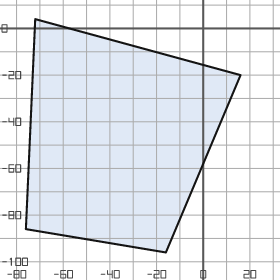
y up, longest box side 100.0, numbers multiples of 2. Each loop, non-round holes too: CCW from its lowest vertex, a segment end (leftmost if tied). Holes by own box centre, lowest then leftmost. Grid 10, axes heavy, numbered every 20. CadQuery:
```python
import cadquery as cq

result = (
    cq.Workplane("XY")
    .moveTo(-16.0, -96.0)
    .lineTo(16.0, -20.0)
    .lineTo(-72.0, 4.0)
    .lineTo(-76.0, -86.0)
    .close()
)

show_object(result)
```